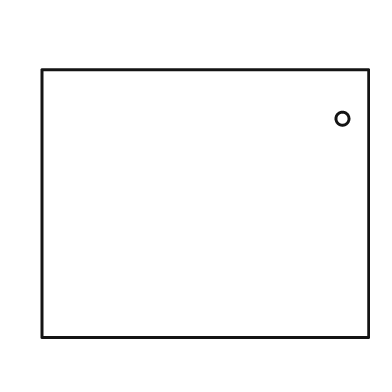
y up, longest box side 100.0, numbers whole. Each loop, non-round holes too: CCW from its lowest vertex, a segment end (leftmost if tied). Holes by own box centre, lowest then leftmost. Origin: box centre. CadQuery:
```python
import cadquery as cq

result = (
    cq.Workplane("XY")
    .moveTo(-50.0, -41.0)
    .lineTo(50.0, -41.0)
    .lineTo(50.0, 41.0)
    .lineTo(-50.0, 41.0)
    .close()
    .moveTo(42.0, 26.0)
    .circle(2.0)
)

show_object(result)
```